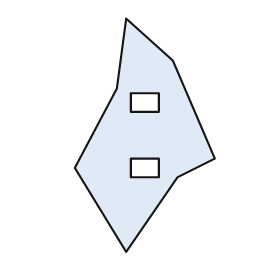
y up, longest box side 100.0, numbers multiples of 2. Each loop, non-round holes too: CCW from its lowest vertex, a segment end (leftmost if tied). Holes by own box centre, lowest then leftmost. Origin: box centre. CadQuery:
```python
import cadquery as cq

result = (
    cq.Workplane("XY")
    .moveTo(-8.0, -50.0)
    .lineTo(14.0, -18.0)
    .lineTo(30.0, -10.0)
    .lineTo(12.0, 32.0)
    .lineTo(-8.0, 50.0)
    .lineTo(-12.0, 20.0)
    .lineTo(-30.0, -14.0)
    .close()
    .moveTo(-6.0, -18.0)
    .lineTo(6.0, -18.0)
    .lineTo(6.0, -10.0)
    .lineTo(-6.0, -10.0)
    .close()
    .moveTo(-6.0, 10.0)
    .lineTo(6.0, 10.0)
    .lineTo(6.0, 18.0)
    .lineTo(-6.0, 18.0)
    .close()
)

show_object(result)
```